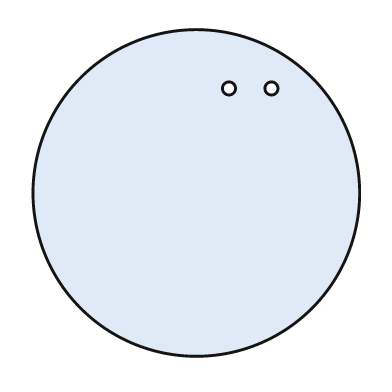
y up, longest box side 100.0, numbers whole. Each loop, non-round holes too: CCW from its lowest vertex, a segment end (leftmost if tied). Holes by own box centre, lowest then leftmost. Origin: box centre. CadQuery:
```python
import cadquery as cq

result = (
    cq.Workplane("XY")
    .moveTo(0.0, 0.0)
    .circle(50.0)
    .moveTo(10.0, 32.0)
    .circle(2.0)
    .moveTo(23.0, 32.0)
    .circle(2.0)
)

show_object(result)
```